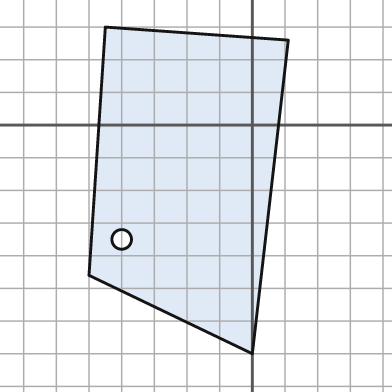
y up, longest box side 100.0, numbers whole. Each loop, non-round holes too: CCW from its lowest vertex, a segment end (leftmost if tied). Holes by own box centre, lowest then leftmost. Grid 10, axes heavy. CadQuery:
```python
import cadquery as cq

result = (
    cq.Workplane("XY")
    .moveTo(0.0, -70.0)
    .lineTo(11.0, 26.0)
    .lineTo(-45.0, 30.0)
    .lineTo(-50.0, -46.0)
    .close()
    .moveTo(-40.0, -35.0)
    .circle(3.0)
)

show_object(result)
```